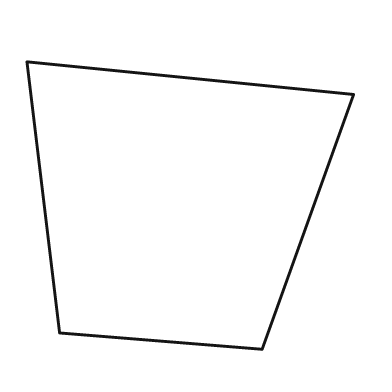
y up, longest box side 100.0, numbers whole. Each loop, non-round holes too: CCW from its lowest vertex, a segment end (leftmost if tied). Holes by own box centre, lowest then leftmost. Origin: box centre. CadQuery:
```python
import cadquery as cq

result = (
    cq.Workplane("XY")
    .moveTo(22.0, -44.0)
    .lineTo(50.0, 34.0)
    .lineTo(-50.0, 44.0)
    .lineTo(-40.0, -39.0)
    .close()
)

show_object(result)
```